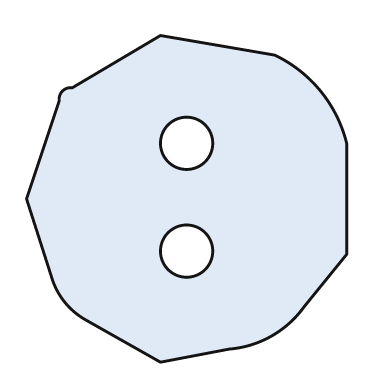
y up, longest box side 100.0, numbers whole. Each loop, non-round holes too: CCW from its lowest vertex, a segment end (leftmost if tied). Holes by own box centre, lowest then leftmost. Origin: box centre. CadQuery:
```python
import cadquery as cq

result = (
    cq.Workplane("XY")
    .moveTo(-8.0, -50.0)
    .lineTo(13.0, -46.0)
    .threePointArc((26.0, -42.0), (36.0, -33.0))
    .lineTo(49.0, -17.0)
    .lineTo(49.0, 17.0)
    .threePointArc((41.0, 33.0), (27.0, 44.0))
    .lineTo(-8.0, 50.0)
    .lineTo(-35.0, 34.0)
    .threePointArc((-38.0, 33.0), (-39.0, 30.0))
    .lineTo(-49.0, 0.0)
    .lineTo(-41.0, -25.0)
    .threePointArc((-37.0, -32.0), (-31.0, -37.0))
    .close()
    .moveTo(0.0, -16.0)
    .circle(8.0)
    .moveTo(0.0, 17.0)
    .circle(8.0)
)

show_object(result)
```